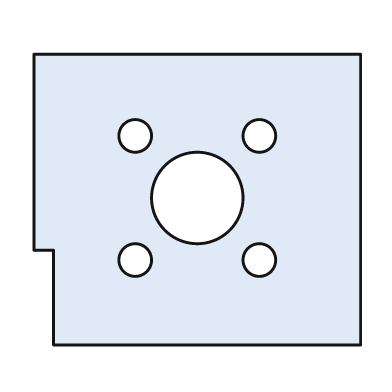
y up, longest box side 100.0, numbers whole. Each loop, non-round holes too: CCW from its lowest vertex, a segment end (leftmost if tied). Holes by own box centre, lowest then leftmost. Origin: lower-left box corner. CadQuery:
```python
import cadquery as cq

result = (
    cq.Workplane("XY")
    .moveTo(6.0, 0.0)
    .lineTo(100.0, 0.0)
    .lineTo(100.0, 89.0)
    .lineTo(0.0, 89.0)
    .lineTo(0.0, 29.0)
    .lineTo(6.0, 29.0)
    .close()
    .moveTo(31.0, 26.0)
    .circle(5.0)
    .moveTo(69.0, 26.0)
    .circle(5.0)
    .moveTo(50.0, 45.0)
    .circle(14.0)
    .moveTo(31.0, 64.0)
    .circle(5.0)
    .moveTo(69.0, 64.0)
    .circle(5.0)
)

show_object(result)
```